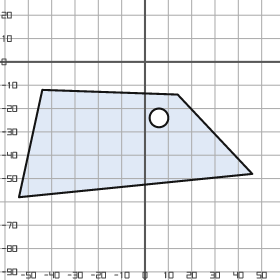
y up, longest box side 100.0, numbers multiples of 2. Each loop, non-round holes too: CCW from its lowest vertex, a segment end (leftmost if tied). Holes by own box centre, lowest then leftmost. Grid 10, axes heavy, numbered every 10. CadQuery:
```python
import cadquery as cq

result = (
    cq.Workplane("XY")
    .moveTo(-54.0, -58.0)
    .lineTo(46.0, -48.0)
    .lineTo(14.0, -14.0)
    .lineTo(-44.0, -12.0)
    .close()
    .moveTo(6.0, -24.0)
    .circle(4.0)
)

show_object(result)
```